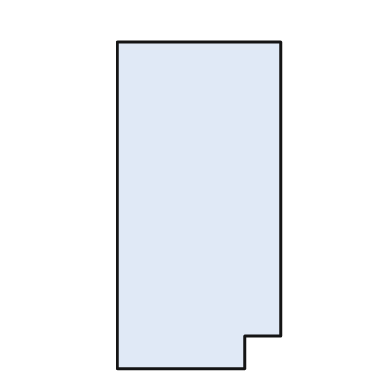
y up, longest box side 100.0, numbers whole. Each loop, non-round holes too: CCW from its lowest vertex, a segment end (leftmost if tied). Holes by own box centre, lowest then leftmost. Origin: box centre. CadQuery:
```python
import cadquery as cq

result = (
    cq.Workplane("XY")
    .moveTo(-25.0, -50.0)
    .lineTo(14.0, -50.0)
    .lineTo(14.0, -40.0)
    .lineTo(25.0, -40.0)
    .lineTo(25.0, 50.0)
    .lineTo(-25.0, 50.0)
    .close()
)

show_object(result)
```